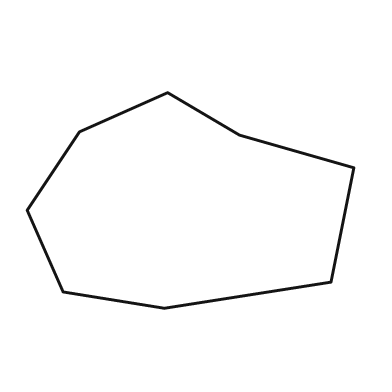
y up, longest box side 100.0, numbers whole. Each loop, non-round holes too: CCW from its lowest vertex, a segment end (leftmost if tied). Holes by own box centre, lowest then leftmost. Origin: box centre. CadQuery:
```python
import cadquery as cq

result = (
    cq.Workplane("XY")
    .moveTo(-8.0, -33.0)
    .lineTo(43.0, -25.0)
    .lineTo(50.0, 10.0)
    .lineTo(15.0, 20.0)
    .lineTo(-7.0, 33.0)
    .lineTo(-34.0, 21.0)
    .lineTo(-50.0, -3.0)
    .lineTo(-39.0, -28.0)
    .close()
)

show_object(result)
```